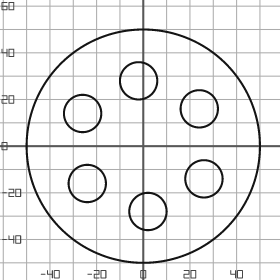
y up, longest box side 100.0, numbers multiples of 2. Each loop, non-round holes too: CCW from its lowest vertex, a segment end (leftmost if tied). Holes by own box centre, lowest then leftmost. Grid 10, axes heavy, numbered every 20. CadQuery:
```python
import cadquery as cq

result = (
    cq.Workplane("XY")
    .moveTo(0.0, 0.0)
    .circle(50.0)
    .moveTo(2.0, -28.0)
    .circle(8.0)
    .moveTo(-24.0, -16.0)
    .circle(8.0)
    .moveTo(26.0, -14.0)
    .circle(8.0)
    .moveTo(-26.0, 14.0)
    .circle(8.0)
    .moveTo(24.0, 16.0)
    .circle(8.0)
    .moveTo(-2.0, 28.0)
    .circle(8.0)
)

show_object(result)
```